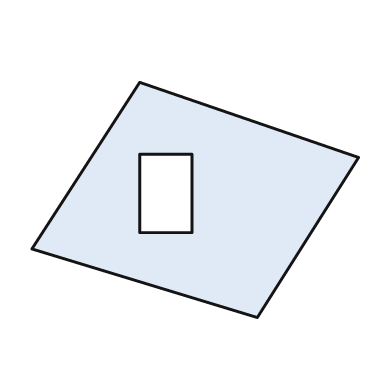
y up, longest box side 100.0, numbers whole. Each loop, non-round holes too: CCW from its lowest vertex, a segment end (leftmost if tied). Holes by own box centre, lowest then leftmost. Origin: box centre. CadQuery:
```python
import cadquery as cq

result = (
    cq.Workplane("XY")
    .moveTo(19.0, -36.0)
    .lineTo(50.0, 13.0)
    .lineTo(-17.0, 36.0)
    .lineTo(-50.0, -15.0)
    .close()
    .moveTo(-17.0, -10.0)
    .lineTo(-1.0, -10.0)
    .lineTo(-1.0, 14.0)
    .lineTo(-17.0, 14.0)
    .close()
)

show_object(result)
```